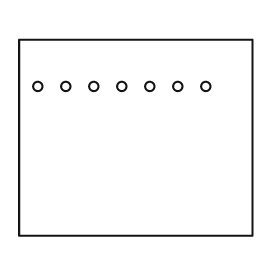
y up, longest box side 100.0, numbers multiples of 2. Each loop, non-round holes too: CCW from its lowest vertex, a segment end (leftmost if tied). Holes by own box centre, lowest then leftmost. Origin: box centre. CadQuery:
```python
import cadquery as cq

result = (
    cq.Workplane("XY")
    .moveTo(-50.0, -42.0)
    .lineTo(50.0, -42.0)
    .lineTo(50.0, 42.0)
    .lineTo(-50.0, 42.0)
    .close()
    .moveTo(-42.0, 22.0)
    .circle(2.0)
    .moveTo(-30.0, 22.0)
    .circle(2.0)
    .moveTo(-18.0, 22.0)
    .circle(2.0)
    .moveTo(-6.0, 22.0)
    .circle(2.0)
    .moveTo(6.0, 22.0)
    .circle(2.0)
    .moveTo(18.0, 22.0)
    .circle(2.0)
    .moveTo(30.0, 22.0)
    .circle(2.0)
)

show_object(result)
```